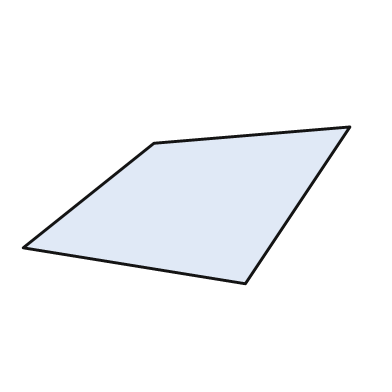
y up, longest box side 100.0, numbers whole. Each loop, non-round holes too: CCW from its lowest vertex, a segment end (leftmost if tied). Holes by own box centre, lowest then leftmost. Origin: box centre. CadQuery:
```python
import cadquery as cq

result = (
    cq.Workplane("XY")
    .moveTo(18.0, -24.0)
    .lineTo(50.0, 24.0)
    .lineTo(-10.0, 19.0)
    .lineTo(-50.0, -13.0)
    .close()
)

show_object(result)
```